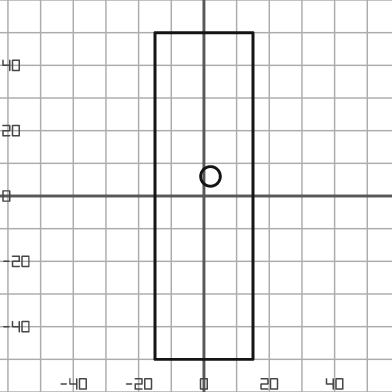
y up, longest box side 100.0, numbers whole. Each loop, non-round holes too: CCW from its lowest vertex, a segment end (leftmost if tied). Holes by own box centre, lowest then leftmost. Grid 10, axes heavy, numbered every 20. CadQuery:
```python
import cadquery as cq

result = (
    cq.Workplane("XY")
    .moveTo(-15.0, -50.0)
    .lineTo(15.0, -50.0)
    .lineTo(15.0, 50.0)
    .lineTo(-15.0, 50.0)
    .close()
    .moveTo(2.0, 6.0)
    .circle(3.0)
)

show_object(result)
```